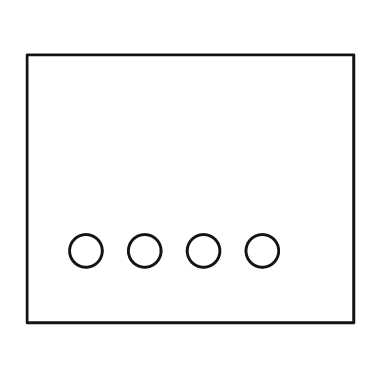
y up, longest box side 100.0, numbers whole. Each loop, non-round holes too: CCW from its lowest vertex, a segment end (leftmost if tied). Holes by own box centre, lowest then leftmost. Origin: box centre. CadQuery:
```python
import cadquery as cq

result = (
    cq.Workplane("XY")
    .moveTo(-50.0, -41.0)
    .lineTo(50.0, -41.0)
    .lineTo(50.0, 41.0)
    .lineTo(-50.0, 41.0)
    .close()
    .moveTo(-32.0, -19.0)
    .circle(5.0)
    .moveTo(-14.0, -19.0)
    .circle(5.0)
    .moveTo(4.0, -19.0)
    .circle(5.0)
    .moveTo(22.0, -19.0)
    .circle(5.0)
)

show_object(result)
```